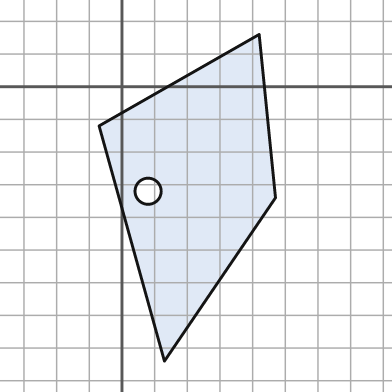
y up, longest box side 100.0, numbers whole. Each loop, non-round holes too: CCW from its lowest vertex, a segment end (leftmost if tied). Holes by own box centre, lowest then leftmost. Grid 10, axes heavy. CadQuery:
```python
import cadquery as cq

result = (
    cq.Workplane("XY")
    .moveTo(13.0, -84.0)
    .lineTo(47.0, -34.0)
    .lineTo(42.0, 16.0)
    .lineTo(-7.0, -12.0)
    .close()
    .moveTo(8.0, -32.0)
    .circle(4.0)
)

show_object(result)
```